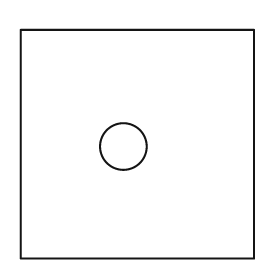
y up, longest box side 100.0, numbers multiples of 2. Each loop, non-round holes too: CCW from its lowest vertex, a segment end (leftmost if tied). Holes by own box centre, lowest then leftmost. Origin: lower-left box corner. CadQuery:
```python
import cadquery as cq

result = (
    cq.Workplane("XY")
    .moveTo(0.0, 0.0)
    .lineTo(100.0, 0.0)
    .lineTo(100.0, 98.0)
    .lineTo(0.0, 98.0)
    .close()
    .moveTo(44.0, 48.0)
    .circle(10.0)
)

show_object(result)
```